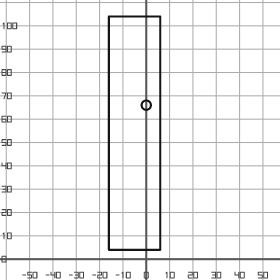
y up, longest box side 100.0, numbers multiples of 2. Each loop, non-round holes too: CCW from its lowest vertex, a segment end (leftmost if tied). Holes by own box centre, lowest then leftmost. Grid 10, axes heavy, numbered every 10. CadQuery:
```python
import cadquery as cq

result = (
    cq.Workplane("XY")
    .moveTo(-16.0, 4.0)
    .lineTo(6.0, 4.0)
    .lineTo(6.0, 104.0)
    .lineTo(-16.0, 104.0)
    .close()
    .moveTo(0.0, 66.0)
    .circle(2.0)
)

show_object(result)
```